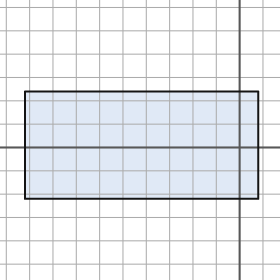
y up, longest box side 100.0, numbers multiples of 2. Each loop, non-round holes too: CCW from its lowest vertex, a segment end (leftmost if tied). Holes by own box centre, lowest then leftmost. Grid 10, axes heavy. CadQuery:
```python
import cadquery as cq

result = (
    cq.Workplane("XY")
    .moveTo(-92.0, -22.0)
    .lineTo(8.0, -22.0)
    .lineTo(8.0, 24.0)
    .lineTo(-92.0, 24.0)
    .close()
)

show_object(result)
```